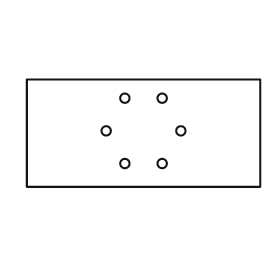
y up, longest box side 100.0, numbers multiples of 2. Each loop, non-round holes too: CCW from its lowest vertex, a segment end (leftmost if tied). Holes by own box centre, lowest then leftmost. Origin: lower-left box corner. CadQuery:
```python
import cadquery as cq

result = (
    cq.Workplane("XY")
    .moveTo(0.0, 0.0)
    .lineTo(100.0, 0.0)
    .lineTo(100.0, 46.0)
    .lineTo(0.0, 46.0)
    .close()
    .moveTo(42.0, 10.0)
    .circle(2.0)
    .moveTo(58.0, 10.0)
    .circle(2.0)
    .moveTo(34.0, 24.0)
    .circle(2.0)
    .moveTo(66.0, 24.0)
    .circle(2.0)
    .moveTo(42.0, 38.0)
    .circle(2.0)
    .moveTo(58.0, 38.0)
    .circle(2.0)
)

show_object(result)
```